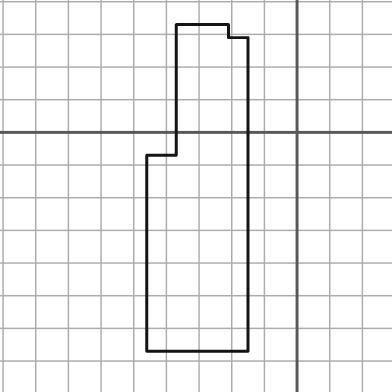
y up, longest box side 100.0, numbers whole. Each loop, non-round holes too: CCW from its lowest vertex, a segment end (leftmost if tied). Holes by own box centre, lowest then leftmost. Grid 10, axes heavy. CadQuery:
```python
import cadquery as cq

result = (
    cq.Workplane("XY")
    .moveTo(-46.0, -67.0)
    .lineTo(-15.0, -67.0)
    .lineTo(-15.0, 29.0)
    .lineTo(-21.0, 29.0)
    .lineTo(-21.0, 33.0)
    .lineTo(-37.0, 33.0)
    .lineTo(-37.0, -7.0)
    .lineTo(-46.0, -7.0)
    .close()
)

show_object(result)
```